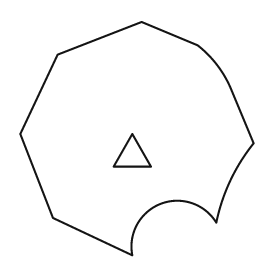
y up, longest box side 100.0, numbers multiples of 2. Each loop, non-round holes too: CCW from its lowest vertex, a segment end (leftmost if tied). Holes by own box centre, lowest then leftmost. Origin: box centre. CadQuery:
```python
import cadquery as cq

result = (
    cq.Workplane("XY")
    .moveTo(-2.0, -50.0)
    .threePointArc((10.0, -28.0), (34.0, -36.0))
    .threePointArc((40.0, -18.0), (50.0, -2.0))
    .lineTo(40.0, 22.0)
    .threePointArc((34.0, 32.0), (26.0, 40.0))
    .lineTo(2.0, 50.0)
    .lineTo(-34.0, 36.0)
    .lineTo(-50.0, 2.0)
    .lineTo(-36.0, -34.0)
    .close()
    .moveTo(-10.0, -12.0)
    .lineTo(6.0, -12.0)
    .lineTo(-2.0, 2.0)
    .close()
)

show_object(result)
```